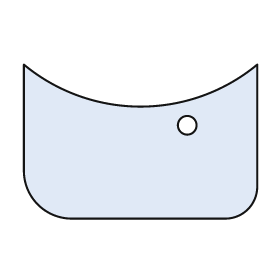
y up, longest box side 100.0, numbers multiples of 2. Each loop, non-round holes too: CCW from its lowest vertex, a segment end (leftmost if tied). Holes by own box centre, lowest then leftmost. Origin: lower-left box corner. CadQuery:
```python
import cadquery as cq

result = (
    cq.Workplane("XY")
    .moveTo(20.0, 0.0)
    .lineTo(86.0, 0.0)
    .threePointArc((96.0, 4.0), (100.0, 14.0))
    .lineTo(100.0, 66.0)
    .threePointArc((50.0, 48.0), (0.0, 66.0))
    .lineTo(0.0, 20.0)
    .threePointArc((6.0, 6.0), (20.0, 0.0))
    .close()
    .moveTo(70.0, 40.0)
    .circle(4.0)
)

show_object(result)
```